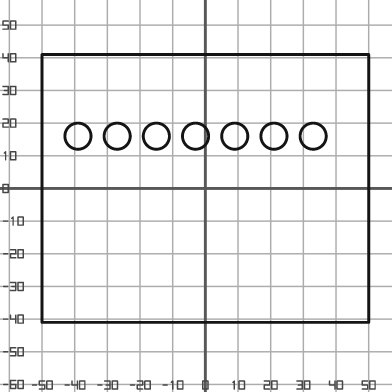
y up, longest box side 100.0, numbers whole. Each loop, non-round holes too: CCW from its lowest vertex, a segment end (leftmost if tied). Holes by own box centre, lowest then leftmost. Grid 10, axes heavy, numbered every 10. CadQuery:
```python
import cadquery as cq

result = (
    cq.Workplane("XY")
    .moveTo(-50.0, -41.0)
    .lineTo(50.0, -41.0)
    .lineTo(50.0, 41.0)
    .lineTo(-50.0, 41.0)
    .close()
    .moveTo(-39.0, 16.0)
    .circle(4.0)
    .moveTo(-27.0, 16.0)
    .circle(4.0)
    .moveTo(-15.0, 16.0)
    .circle(4.0)
    .moveTo(-3.0, 16.0)
    .circle(4.0)
    .moveTo(9.0, 16.0)
    .circle(4.0)
    .moveTo(21.0, 16.0)
    .circle(4.0)
    .moveTo(33.0, 16.0)
    .circle(4.0)
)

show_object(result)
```